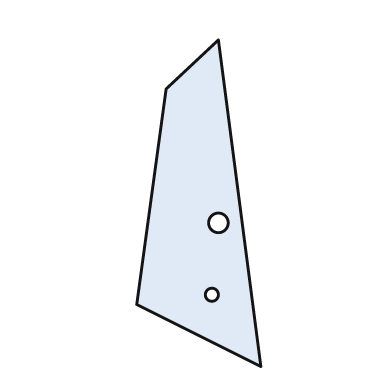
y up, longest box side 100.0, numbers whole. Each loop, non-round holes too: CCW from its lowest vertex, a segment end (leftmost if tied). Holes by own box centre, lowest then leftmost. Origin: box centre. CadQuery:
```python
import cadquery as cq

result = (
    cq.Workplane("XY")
    .moveTo(19.0, -50.0)
    .lineTo(6.0, 50.0)
    .lineTo(-10.0, 35.0)
    .lineTo(-19.0, -31.0)
    .close()
    .moveTo(4.0, -28.0)
    .circle(2.0)
    .moveTo(6.0, -6.0)
    .circle(3.0)
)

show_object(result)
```